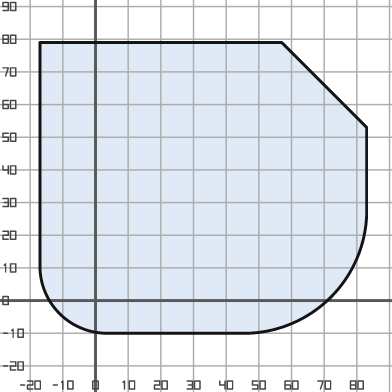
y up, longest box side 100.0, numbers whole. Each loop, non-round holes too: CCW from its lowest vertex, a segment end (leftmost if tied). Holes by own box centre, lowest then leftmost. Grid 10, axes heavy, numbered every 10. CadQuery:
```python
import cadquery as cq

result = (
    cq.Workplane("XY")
    .moveTo(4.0, -10.0)
    .lineTo(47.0, -10.0)
    .threePointArc((72.0, 1.0), (83.0, 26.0))
    .lineTo(83.0, 53.0)
    .lineTo(57.0, 79.0)
    .lineTo(-17.0, 79.0)
    .lineTo(-17.0, 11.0)
    .threePointArc((-11.0, -4.0), (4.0, -10.0))
    .close()
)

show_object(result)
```